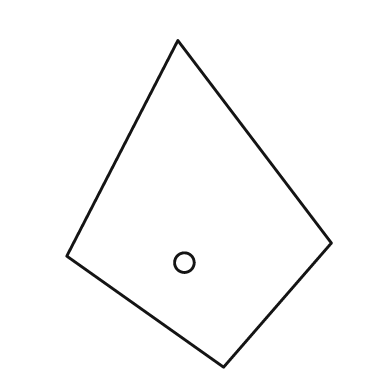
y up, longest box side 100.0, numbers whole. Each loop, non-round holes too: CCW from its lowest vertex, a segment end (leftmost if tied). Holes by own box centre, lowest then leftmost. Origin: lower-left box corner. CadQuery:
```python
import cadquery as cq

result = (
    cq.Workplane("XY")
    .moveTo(48.0, 0.0)
    .lineTo(81.0, 38.0)
    .lineTo(34.0, 100.0)
    .lineTo(0.0, 34.0)
    .close()
    .moveTo(36.0, 32.0)
    .circle(3.0)
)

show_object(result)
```